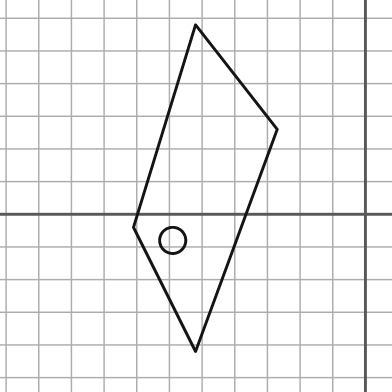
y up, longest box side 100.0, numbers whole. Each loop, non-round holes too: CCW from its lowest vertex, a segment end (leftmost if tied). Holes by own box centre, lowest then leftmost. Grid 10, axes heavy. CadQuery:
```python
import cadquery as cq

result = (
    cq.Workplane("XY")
    .moveTo(-52.0, -42.0)
    .lineTo(-27.0, 26.0)
    .lineTo(-52.0, 58.0)
    .lineTo(-71.0, -4.0)
    .close()
    .moveTo(-59.0, -8.0)
    .circle(4.0)
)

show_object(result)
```